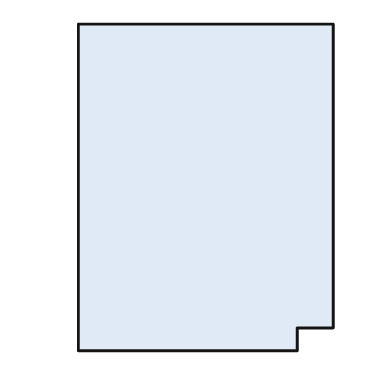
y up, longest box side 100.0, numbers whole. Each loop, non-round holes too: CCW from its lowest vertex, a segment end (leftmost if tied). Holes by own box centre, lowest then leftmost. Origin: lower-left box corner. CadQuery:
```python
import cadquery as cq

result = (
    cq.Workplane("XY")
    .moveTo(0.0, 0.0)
    .lineTo(67.0, 0.0)
    .lineTo(67.0, 7.0)
    .lineTo(78.0, 7.0)
    .lineTo(78.0, 100.0)
    .lineTo(0.0, 100.0)
    .close()
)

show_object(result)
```